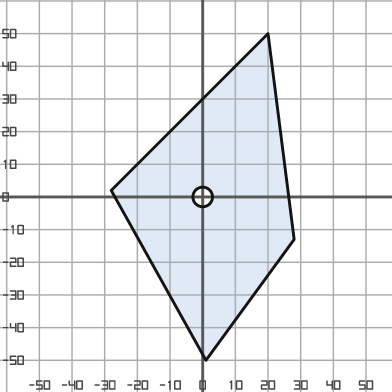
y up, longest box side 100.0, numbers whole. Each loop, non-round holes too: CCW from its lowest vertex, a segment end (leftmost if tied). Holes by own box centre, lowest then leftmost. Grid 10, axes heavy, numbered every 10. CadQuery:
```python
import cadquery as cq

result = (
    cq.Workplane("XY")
    .moveTo(1.0, -50.0)
    .lineTo(28.0, -13.0)
    .lineTo(20.0, 50.0)
    .lineTo(-28.0, 2.0)
    .close()
    .moveTo(0.0, 0.0)
    .circle(3.0)
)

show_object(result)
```